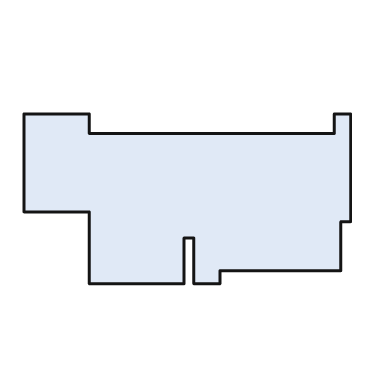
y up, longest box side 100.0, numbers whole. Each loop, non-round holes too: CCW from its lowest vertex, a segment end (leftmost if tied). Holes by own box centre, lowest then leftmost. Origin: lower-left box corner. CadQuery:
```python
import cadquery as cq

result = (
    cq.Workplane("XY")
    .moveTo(20.0, 0.0)
    .lineTo(49.0, 0.0)
    .lineTo(49.0, 14.0)
    .lineTo(52.0, 14.0)
    .lineTo(52.0, 0.0)
    .lineTo(60.0, 0.0)
    .lineTo(60.0, 4.0)
    .lineTo(97.0, 4.0)
    .lineTo(97.0, 19.0)
    .lineTo(100.0, 19.0)
    .lineTo(100.0, 52.0)
    .lineTo(95.0, 52.0)
    .lineTo(95.0, 46.0)
    .lineTo(20.0, 46.0)
    .lineTo(20.0, 52.0)
    .lineTo(0.0, 52.0)
    .lineTo(0.0, 22.0)
    .lineTo(20.0, 22.0)
    .close()
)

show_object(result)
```